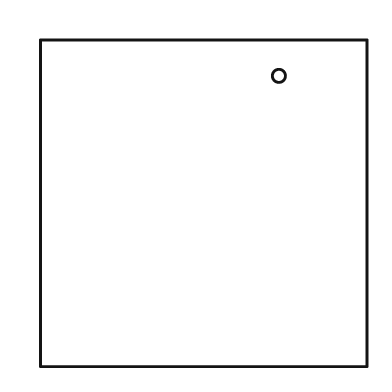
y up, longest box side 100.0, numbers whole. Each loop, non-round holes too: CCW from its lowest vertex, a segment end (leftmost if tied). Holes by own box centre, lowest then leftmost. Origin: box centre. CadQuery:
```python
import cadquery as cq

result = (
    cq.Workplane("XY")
    .moveTo(-50.0, -50.0)
    .lineTo(50.0, -50.0)
    .lineTo(50.0, 50.0)
    .lineTo(-50.0, 50.0)
    .close()
    .moveTo(23.0, 39.0)
    .circle(2.0)
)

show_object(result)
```